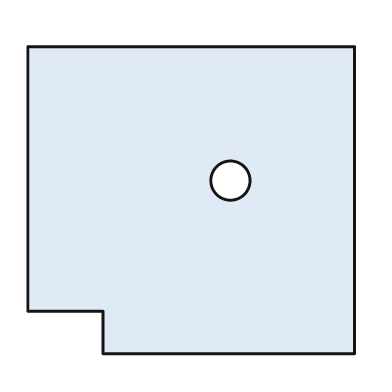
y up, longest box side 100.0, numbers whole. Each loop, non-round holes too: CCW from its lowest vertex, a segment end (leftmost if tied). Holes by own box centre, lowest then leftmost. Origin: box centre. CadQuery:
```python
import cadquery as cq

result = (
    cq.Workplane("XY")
    .moveTo(-27.0, -47.0)
    .lineTo(50.0, -47.0)
    .lineTo(50.0, 47.0)
    .lineTo(-50.0, 47.0)
    .lineTo(-50.0, -34.0)
    .lineTo(-27.0, -34.0)
    .close()
    .moveTo(12.0, 6.0)
    .circle(6.0)
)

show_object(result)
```